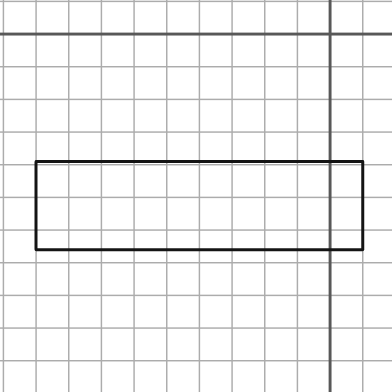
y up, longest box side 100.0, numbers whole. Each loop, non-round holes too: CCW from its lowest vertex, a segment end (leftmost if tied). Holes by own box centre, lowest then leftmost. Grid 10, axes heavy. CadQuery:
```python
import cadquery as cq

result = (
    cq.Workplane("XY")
    .moveTo(-90.0, -66.0)
    .lineTo(10.0, -66.0)
    .lineTo(10.0, -39.0)
    .lineTo(-90.0, -39.0)
    .close()
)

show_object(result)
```